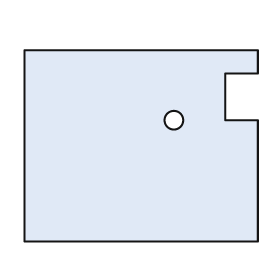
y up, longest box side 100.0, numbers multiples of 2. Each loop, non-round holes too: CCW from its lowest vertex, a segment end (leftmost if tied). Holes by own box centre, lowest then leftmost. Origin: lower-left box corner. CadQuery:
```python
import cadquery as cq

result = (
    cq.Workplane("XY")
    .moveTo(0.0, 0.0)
    .lineTo(100.0, 0.0)
    .lineTo(100.0, 52.0)
    .lineTo(86.0, 52.0)
    .lineTo(86.0, 72.0)
    .lineTo(100.0, 72.0)
    .lineTo(100.0, 82.0)
    .lineTo(0.0, 82.0)
    .close()
    .moveTo(64.0, 52.0)
    .circle(4.0)
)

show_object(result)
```